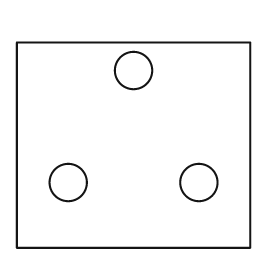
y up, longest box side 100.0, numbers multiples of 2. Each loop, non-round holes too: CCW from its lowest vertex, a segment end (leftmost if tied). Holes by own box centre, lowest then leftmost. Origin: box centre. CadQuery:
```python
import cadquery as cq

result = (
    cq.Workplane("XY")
    .moveTo(-50.0, -44.0)
    .lineTo(50.0, -44.0)
    .lineTo(50.0, 44.0)
    .lineTo(-50.0, 44.0)
    .close()
    .moveTo(-28.0, -16.0)
    .circle(8.0)
    .moveTo(28.0, -16.0)
    .circle(8.0)
    .moveTo(0.0, 32.0)
    .circle(8.0)
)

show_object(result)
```